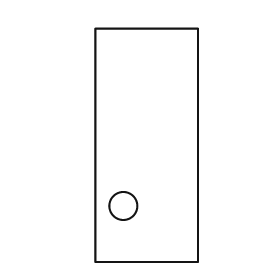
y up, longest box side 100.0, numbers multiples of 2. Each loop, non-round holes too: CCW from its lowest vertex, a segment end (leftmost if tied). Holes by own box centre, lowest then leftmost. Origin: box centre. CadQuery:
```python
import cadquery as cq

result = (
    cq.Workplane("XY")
    .moveTo(-22.0, -50.0)
    .lineTo(22.0, -50.0)
    .lineTo(22.0, 50.0)
    .lineTo(-22.0, 50.0)
    .close()
    .moveTo(-10.0, -26.0)
    .circle(6.0)
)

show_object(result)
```